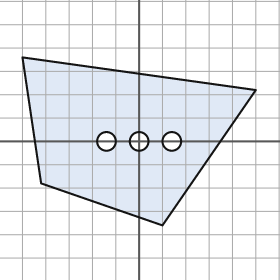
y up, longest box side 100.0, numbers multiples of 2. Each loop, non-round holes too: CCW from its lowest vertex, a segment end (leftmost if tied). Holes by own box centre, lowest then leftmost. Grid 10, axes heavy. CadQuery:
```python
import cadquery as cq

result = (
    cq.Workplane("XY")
    .moveTo(10.0, -36.0)
    .lineTo(50.0, 22.0)
    .lineTo(-50.0, 36.0)
    .lineTo(-42.0, -18.0)
    .close()
    .moveTo(-14.0, 0.0)
    .circle(4.0)
    .moveTo(0.0, 0.0)
    .circle(4.0)
    .moveTo(14.0, 0.0)
    .circle(4.0)
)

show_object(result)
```